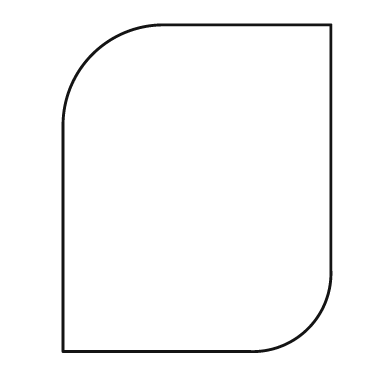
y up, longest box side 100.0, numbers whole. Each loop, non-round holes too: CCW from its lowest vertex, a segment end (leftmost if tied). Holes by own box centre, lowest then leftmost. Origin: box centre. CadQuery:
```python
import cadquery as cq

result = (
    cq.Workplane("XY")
    .moveTo(-41.0, -50.0)
    .lineTo(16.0, -50.0)
    .threePointArc((34.0, -43.0), (41.0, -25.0))
    .lineTo(41.0, 50.0)
    .lineTo(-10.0, 50.0)
    .threePointArc((-32.0, 41.0), (-41.0, 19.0))
    .close()
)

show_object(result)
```